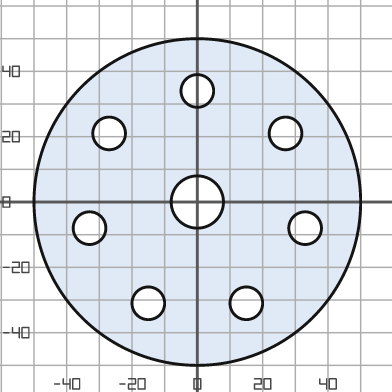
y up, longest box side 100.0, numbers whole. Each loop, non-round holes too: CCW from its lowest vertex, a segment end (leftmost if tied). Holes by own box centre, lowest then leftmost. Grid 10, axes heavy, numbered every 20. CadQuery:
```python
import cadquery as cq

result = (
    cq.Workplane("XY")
    .moveTo(0.0, 0.0)
    .circle(50.0)
    .moveTo(-15.0, -31.0)
    .circle(5.0)
    .moveTo(15.0, -31.0)
    .circle(5.0)
    .moveTo(-33.0, -8.0)
    .circle(5.0)
    .moveTo(33.0, -8.0)
    .circle(5.0)
    .moveTo(0.0, 0.0)
    .circle(8.0)
    .moveTo(-27.0, 21.0)
    .circle(5.0)
    .moveTo(27.0, 21.0)
    .circle(5.0)
    .moveTo(0.0, 34.0)
    .circle(5.0)
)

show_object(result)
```